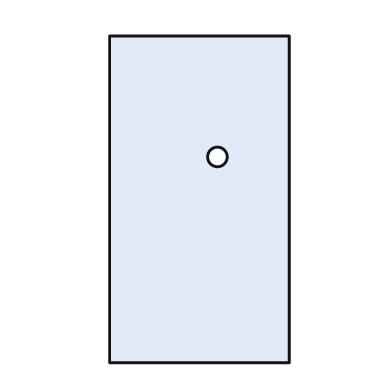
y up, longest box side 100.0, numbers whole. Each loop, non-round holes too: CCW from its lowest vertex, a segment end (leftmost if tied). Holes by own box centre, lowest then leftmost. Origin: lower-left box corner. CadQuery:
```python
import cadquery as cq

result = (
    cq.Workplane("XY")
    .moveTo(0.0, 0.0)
    .lineTo(55.0, 0.0)
    .lineTo(55.0, 100.0)
    .lineTo(0.0, 100.0)
    .close()
    .moveTo(33.0, 63.0)
    .circle(3.0)
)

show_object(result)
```